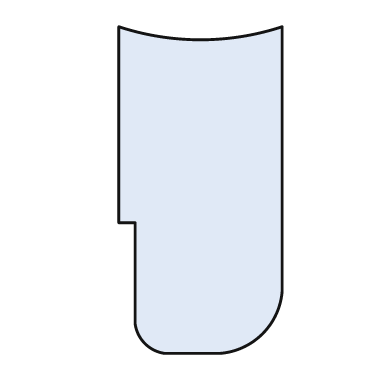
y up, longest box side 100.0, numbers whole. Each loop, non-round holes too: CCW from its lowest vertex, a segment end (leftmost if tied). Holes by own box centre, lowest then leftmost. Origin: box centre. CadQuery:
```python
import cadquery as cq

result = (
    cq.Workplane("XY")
    .moveTo(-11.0, -50.0)
    .lineTo(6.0, -50.0)
    .threePointArc((19.0, -44.0), (25.0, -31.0))
    .lineTo(25.0, 50.0)
    .threePointArc((0.0, 46.0), (-25.0, 50.0))
    .lineTo(-25.0, -10.0)
    .lineTo(-20.0, -10.0)
    .lineTo(-20.0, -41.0)
    .threePointArc((-17.0, -47.0), (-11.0, -50.0))
    .close()
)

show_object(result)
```